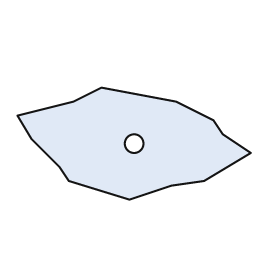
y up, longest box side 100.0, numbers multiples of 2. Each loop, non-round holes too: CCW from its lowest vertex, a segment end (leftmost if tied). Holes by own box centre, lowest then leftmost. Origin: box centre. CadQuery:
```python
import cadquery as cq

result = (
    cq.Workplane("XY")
    .moveTo(-2.0, -24.0)
    .lineTo(16.0, -18.0)
    .lineTo(30.0, -16.0)
    .lineTo(50.0, -4.0)
    .lineTo(38.0, 4.0)
    .lineTo(34.0, 10.0)
    .lineTo(18.0, 18.0)
    .lineTo(-14.0, 24.0)
    .lineTo(-26.0, 18.0)
    .lineTo(-50.0, 12.0)
    .lineTo(-44.0, 2.0)
    .lineTo(-32.0, -10.0)
    .lineTo(-28.0, -16.0)
    .close()
    .moveTo(0.0, 0.0)
    .circle(4.0)
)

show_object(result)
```